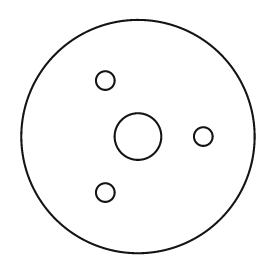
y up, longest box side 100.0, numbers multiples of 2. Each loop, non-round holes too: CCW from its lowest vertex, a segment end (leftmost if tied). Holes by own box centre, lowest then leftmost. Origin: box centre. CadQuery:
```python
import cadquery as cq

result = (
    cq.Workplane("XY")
    .moveTo(0.0, 0.0)
    .circle(50.0)
    .moveTo(-14.0, -24.0)
    .circle(4.0)
    .moveTo(0.0, 0.0)
    .circle(10.0)
    .moveTo(28.0, 0.0)
    .circle(4.0)
    .moveTo(-14.0, 24.0)
    .circle(4.0)
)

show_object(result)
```